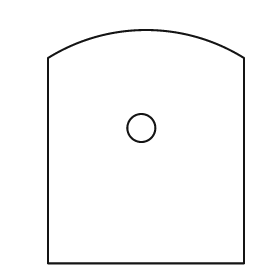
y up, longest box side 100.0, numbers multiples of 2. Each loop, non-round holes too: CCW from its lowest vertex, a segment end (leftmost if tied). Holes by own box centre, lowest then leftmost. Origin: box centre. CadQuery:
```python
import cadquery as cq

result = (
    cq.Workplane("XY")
    .moveTo(-42.0, -50.0)
    .lineTo(42.0, -50.0)
    .lineTo(42.0, 38.0)
    .threePointArc((0.0, 50.0), (-42.0, 38.0))
    .close()
    .moveTo(-2.0, 8.0)
    .circle(6.0)
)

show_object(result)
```